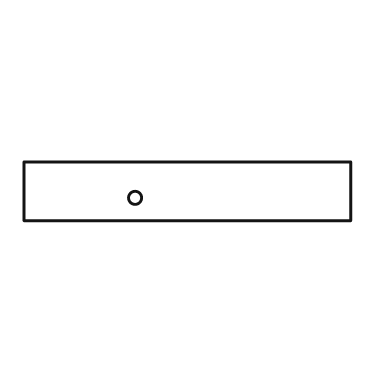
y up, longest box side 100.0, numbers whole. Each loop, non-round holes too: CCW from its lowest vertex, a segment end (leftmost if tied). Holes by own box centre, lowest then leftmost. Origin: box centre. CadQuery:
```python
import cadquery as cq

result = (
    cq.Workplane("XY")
    .moveTo(-50.0, -9.0)
    .lineTo(50.0, -9.0)
    .lineTo(50.0, 9.0)
    .lineTo(-50.0, 9.0)
    .close()
    .moveTo(-16.0, -2.0)
    .circle(2.0)
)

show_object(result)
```